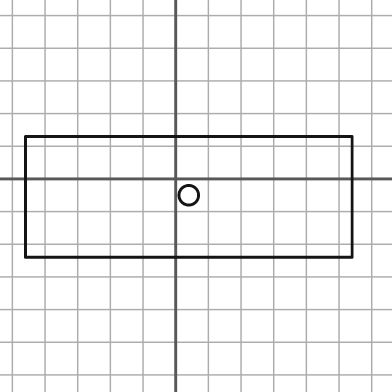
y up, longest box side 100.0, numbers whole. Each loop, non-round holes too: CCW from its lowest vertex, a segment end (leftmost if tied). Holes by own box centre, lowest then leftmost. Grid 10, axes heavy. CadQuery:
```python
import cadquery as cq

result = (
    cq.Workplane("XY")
    .moveTo(-46.0, -24.0)
    .lineTo(54.0, -24.0)
    .lineTo(54.0, 13.0)
    .lineTo(-46.0, 13.0)
    .close()
    .moveTo(4.0, -5.0)
    .circle(3.0)
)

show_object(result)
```